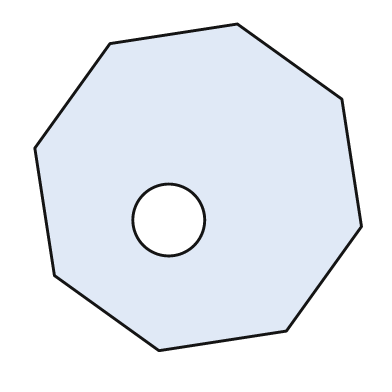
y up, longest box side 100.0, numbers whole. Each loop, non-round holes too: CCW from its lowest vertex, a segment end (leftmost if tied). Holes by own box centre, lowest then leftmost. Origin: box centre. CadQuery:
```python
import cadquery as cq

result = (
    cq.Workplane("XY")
    .moveTo(-12.0, -50.0)
    .lineTo(27.0, -44.0)
    .lineTo(50.0, -12.0)
    .lineTo(44.0, 27.0)
    .lineTo(12.0, 50.0)
    .lineTo(-27.0, 44.0)
    .lineTo(-50.0, 12.0)
    .lineTo(-44.0, -27.0)
    .close()
    .moveTo(-9.0, -10.0)
    .circle(11.0)
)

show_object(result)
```